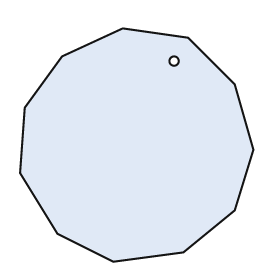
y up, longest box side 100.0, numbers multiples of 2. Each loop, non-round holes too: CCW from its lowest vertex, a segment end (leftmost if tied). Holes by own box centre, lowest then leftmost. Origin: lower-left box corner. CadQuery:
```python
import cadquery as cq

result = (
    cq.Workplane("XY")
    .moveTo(40.0, 0.0)
    .lineTo(70.0, 4.0)
    .lineTo(92.0, 22.0)
    .lineTo(100.0, 48.0)
    .lineTo(92.0, 76.0)
    .lineTo(72.0, 96.0)
    .lineTo(44.0, 100.0)
    .lineTo(18.0, 88.0)
    .lineTo(2.0, 66.0)
    .lineTo(0.0, 38.0)
    .lineTo(16.0, 12.0)
    .close()
    .moveTo(66.0, 86.0)
    .circle(2.0)
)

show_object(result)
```